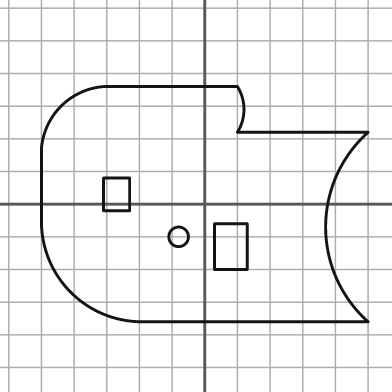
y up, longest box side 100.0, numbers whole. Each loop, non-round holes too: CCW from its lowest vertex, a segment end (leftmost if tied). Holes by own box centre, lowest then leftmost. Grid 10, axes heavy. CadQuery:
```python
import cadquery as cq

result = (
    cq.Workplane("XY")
    .moveTo(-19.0, -36.0)
    .lineTo(50.0, -36.0)
    .threePointArc((37.0, -7.0), (50.0, 22.0))
    .lineTo(10.0, 22.0)
    .threePointArc((12.0, 29.0), (10.0, 36.0))
    .lineTo(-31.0, 36.0)
    .threePointArc((-44.0, 30.0), (-50.0, 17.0))
    .lineTo(-50.0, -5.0)
    .threePointArc((-41.0, -27.0), (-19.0, -36.0))
    .close()
    .moveTo(3.0, -20.0)
    .lineTo(13.0, -20.0)
    .lineTo(13.0, -6.0)
    .lineTo(3.0, -6.0)
    .close()
    .moveTo(-8.0, -10.0)
    .circle(3.0)
    .moveTo(-31.0, -2.0)
    .lineTo(-23.0, -2.0)
    .lineTo(-23.0, 8.0)
    .lineTo(-31.0, 8.0)
    .close()
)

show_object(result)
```